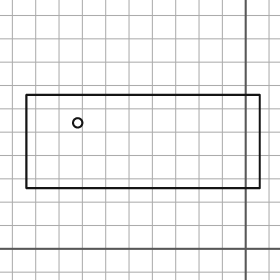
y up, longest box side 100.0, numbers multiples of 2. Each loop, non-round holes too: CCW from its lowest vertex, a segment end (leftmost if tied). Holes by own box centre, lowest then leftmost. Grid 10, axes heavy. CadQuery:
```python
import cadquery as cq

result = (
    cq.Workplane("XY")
    .moveTo(-94.0, 26.0)
    .lineTo(6.0, 26.0)
    .lineTo(6.0, 66.0)
    .lineTo(-94.0, 66.0)
    .close()
    .moveTo(-72.0, 54.0)
    .circle(2.0)
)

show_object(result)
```